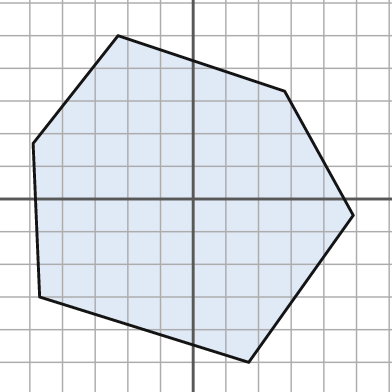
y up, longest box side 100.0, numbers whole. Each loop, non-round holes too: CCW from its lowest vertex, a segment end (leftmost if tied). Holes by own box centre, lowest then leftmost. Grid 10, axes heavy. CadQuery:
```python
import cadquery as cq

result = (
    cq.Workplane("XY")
    .moveTo(17.0, -50.0)
    .lineTo(49.0, -5.0)
    .lineTo(28.0, 33.0)
    .lineTo(-23.0, 50.0)
    .lineTo(-49.0, 17.0)
    .lineTo(-47.0, -30.0)
    .close()
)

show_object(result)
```